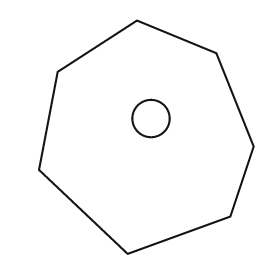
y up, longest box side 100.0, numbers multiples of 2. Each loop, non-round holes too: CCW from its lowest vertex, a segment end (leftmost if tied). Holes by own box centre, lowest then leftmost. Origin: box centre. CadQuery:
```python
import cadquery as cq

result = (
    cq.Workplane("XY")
    .moveTo(-8.0, -50.0)
    .lineTo(36.0, -34.0)
    .lineTo(46.0, -4.0)
    .lineTo(30.0, 36.0)
    .lineTo(-4.0, 50.0)
    .lineTo(-38.0, 28.0)
    .lineTo(-46.0, -14.0)
    .close()
    .moveTo(2.0, 8.0)
    .circle(8.0)
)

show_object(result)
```